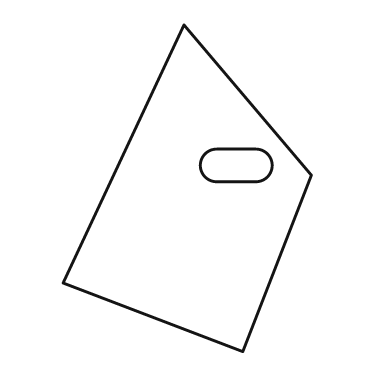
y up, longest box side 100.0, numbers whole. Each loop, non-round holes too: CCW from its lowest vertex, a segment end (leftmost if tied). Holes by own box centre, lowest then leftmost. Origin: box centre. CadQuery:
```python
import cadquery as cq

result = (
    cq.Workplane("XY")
    .moveTo(17.0, -50.0)
    .lineTo(38.0, 4.0)
    .lineTo(-1.0, 50.0)
    .lineTo(-38.0, -29.0)
    .close()
    .moveTo(9.0, 2.0)
    .lineTo(21.0, 2.0)
    .threePointArc((26.0, 7.0), (21.0, 12.0))
    .lineTo(9.0, 12.0)
    .threePointArc((4.0, 7.0), (9.0, 2.0))
    .close()
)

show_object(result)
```